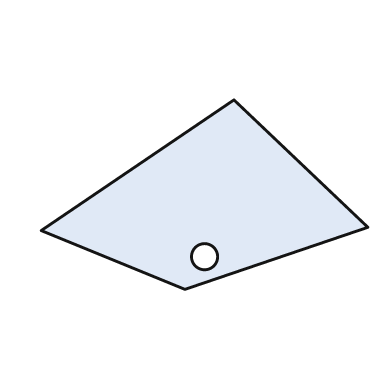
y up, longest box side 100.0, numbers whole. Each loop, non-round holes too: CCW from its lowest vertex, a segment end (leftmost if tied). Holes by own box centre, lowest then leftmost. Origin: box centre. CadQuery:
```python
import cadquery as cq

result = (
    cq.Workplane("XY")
    .moveTo(-6.0, -29.0)
    .lineTo(50.0, -10.0)
    .lineTo(9.0, 29.0)
    .lineTo(-50.0, -11.0)
    .close()
    .moveTo(0.0, -19.0)
    .circle(4.0)
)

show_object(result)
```